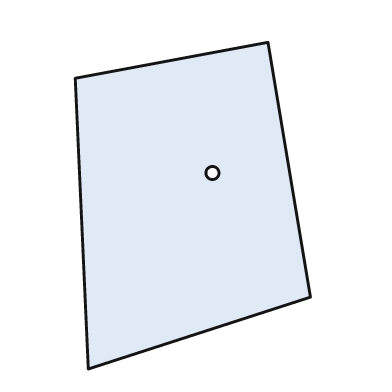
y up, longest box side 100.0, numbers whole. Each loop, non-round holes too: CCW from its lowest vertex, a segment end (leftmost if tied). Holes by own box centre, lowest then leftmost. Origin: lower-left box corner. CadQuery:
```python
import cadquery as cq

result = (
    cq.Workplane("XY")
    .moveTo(4.0, 0.0)
    .lineTo(72.0, 22.0)
    .lineTo(59.0, 100.0)
    .lineTo(0.0, 89.0)
    .close()
    .moveTo(42.0, 60.0)
    .circle(2.0)
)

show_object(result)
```